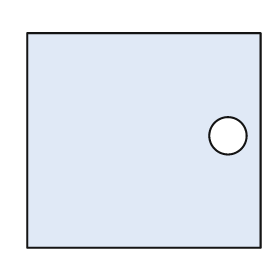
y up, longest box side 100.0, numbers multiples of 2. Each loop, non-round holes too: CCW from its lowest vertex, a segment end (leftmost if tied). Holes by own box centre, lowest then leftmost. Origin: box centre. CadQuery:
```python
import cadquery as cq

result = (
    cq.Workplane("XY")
    .moveTo(-50.0, -46.0)
    .lineTo(50.0, -46.0)
    .lineTo(50.0, 46.0)
    .lineTo(-50.0, 46.0)
    .close()
    .moveTo(36.0, 2.0)
    .circle(8.0)
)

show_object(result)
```